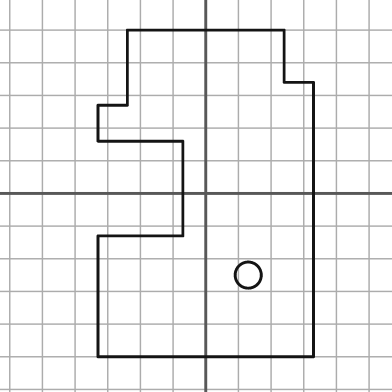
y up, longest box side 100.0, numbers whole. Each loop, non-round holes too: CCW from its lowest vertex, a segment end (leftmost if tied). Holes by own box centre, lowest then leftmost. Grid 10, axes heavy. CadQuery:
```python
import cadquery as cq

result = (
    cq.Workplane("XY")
    .moveTo(-33.0, -50.0)
    .lineTo(33.0, -50.0)
    .lineTo(33.0, 34.0)
    .lineTo(24.0, 34.0)
    .lineTo(24.0, 50.0)
    .lineTo(-24.0, 50.0)
    .lineTo(-24.0, 27.0)
    .lineTo(-33.0, 27.0)
    .lineTo(-33.0, 16.0)
    .lineTo(-7.0, 16.0)
    .lineTo(-7.0, -13.0)
    .lineTo(-33.0, -13.0)
    .close()
    .moveTo(13.0, -25.0)
    .circle(4.0)
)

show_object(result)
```